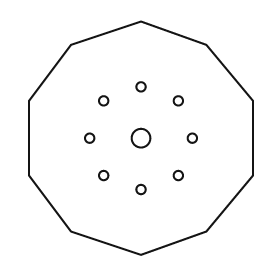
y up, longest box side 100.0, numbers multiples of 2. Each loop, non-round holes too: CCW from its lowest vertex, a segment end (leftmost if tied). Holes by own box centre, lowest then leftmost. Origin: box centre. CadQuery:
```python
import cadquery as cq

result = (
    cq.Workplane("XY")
    .moveTo(0.0, -50.0)
    .lineTo(28.0, -40.0)
    .lineTo(48.0, -16.0)
    .lineTo(48.0, 16.0)
    .lineTo(28.0, 40.0)
    .lineTo(0.0, 50.0)
    .lineTo(-30.0, 40.0)
    .lineTo(-48.0, 16.0)
    .lineTo(-48.0, -16.0)
    .lineTo(-30.0, -40.0)
    .close()
    .moveTo(0.0, -22.0)
    .circle(2.0)
    .moveTo(-16.0, -16.0)
    .circle(2.0)
    .moveTo(16.0, -16.0)
    .circle(2.0)
    .moveTo(-22.0, 0.0)
    .circle(2.0)
    .moveTo(0.0, 0.0)
    .circle(4.0)
    .moveTo(22.0, 0.0)
    .circle(2.0)
    .moveTo(-16.0, 16.0)
    .circle(2.0)
    .moveTo(16.0, 16.0)
    .circle(2.0)
    .moveTo(0.0, 22.0)
    .circle(2.0)
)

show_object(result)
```